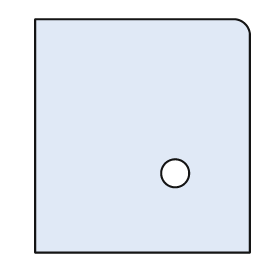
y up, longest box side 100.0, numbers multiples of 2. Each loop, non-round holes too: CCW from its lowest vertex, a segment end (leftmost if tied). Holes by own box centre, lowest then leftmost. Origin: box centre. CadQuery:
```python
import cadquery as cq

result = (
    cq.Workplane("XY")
    .moveTo(-46.0, -50.0)
    .lineTo(46.0, -50.0)
    .lineTo(46.0, 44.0)
    .threePointArc((44.0, 48.0), (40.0, 50.0))
    .lineTo(-46.0, 50.0)
    .close()
    .moveTo(14.0, -16.0)
    .circle(6.0)
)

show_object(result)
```